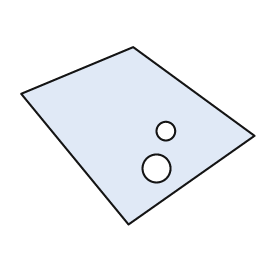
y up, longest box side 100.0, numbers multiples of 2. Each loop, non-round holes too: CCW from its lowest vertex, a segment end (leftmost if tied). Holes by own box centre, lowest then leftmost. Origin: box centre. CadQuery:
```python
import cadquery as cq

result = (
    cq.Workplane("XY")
    .moveTo(-4.0, -38.0)
    .lineTo(50.0, 0.0)
    .lineTo(-2.0, 38.0)
    .lineTo(-50.0, 18.0)
    .close()
    .moveTo(8.0, -14.0)
    .circle(6.0)
    .moveTo(12.0, 2.0)
    .circle(4.0)
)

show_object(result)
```